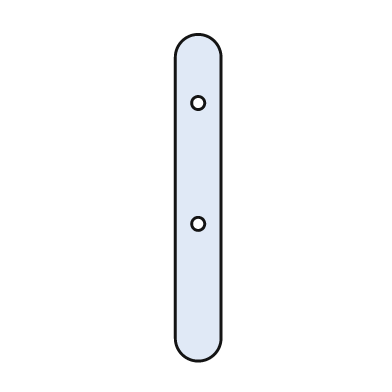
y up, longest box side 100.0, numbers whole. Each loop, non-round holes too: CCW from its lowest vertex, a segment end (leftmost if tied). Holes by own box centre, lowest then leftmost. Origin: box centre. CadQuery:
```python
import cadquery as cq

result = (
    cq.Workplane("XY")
    .moveTo(-7.0, -43.0)
    .threePointArc((0.0, -50.0), (7.0, -43.0))
    .lineTo(7.0, 43.0)
    .threePointArc((0.0, 50.0), (-7.0, 43.0))
    .close()
    .moveTo(0.0, -8.0)
    .circle(2.0)
    .moveTo(0.0, 29.0)
    .circle(2.0)
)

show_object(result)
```